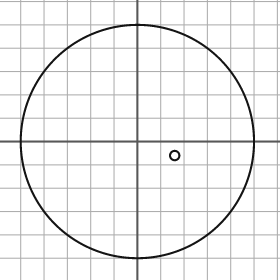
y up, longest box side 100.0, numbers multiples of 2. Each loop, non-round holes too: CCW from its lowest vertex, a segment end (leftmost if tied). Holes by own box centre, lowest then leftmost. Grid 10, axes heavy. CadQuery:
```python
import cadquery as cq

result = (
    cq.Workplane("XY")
    .moveTo(0.0, 0.0)
    .circle(50.0)
    .moveTo(16.0, -6.0)
    .circle(2.0)
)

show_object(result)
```